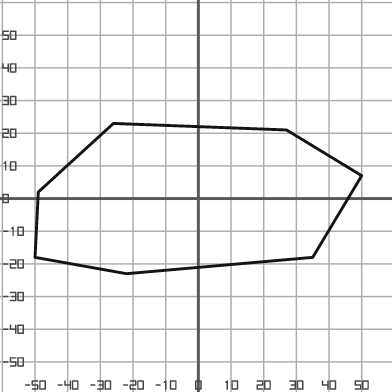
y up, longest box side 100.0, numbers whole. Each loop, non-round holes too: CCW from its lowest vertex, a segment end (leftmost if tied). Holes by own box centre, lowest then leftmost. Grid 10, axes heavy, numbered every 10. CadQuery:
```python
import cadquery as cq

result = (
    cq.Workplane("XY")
    .moveTo(-22.0, -23.0)
    .lineTo(35.0, -18.0)
    .lineTo(50.0, 7.0)
    .lineTo(27.0, 21.0)
    .lineTo(-26.0, 23.0)
    .lineTo(-49.0, 2.0)
    .lineTo(-50.0, -18.0)
    .close()
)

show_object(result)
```